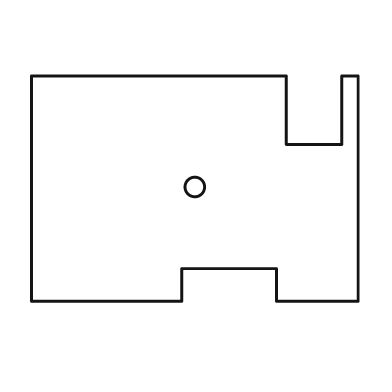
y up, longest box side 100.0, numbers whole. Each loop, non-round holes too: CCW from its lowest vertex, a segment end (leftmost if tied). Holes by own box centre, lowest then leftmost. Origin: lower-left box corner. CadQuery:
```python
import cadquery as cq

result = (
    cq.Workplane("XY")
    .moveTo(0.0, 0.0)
    .lineTo(46.0, 0.0)
    .lineTo(46.0, 10.0)
    .lineTo(75.0, 10.0)
    .lineTo(75.0, 0.0)
    .lineTo(100.0, 0.0)
    .lineTo(100.0, 69.0)
    .lineTo(95.0, 69.0)
    .lineTo(95.0, 48.0)
    .lineTo(78.0, 48.0)
    .lineTo(78.0, 69.0)
    .lineTo(0.0, 69.0)
    .close()
    .moveTo(50.0, 35.0)
    .circle(3.0)
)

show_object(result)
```